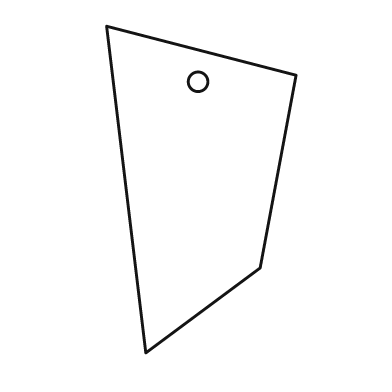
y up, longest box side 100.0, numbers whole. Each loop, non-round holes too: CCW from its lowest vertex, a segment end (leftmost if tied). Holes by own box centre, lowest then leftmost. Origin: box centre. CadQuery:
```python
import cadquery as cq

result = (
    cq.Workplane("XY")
    .moveTo(-17.0, -50.0)
    .lineTo(18.0, -24.0)
    .lineTo(29.0, 35.0)
    .lineTo(-29.0, 50.0)
    .close()
    .moveTo(-1.0, 33.0)
    .circle(3.0)
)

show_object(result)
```